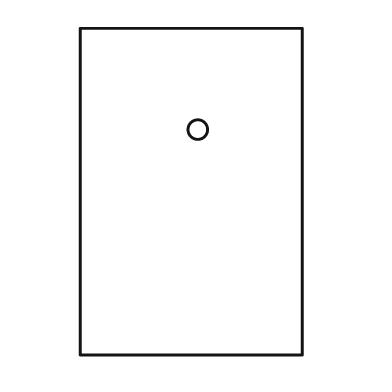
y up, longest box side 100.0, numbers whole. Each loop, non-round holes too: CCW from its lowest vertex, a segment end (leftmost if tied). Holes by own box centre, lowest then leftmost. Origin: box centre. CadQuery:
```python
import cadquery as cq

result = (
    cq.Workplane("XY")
    .moveTo(-34.0, -50.0)
    .lineTo(34.0, -50.0)
    .lineTo(34.0, 50.0)
    .lineTo(-34.0, 50.0)
    .close()
    .moveTo(2.0, 19.0)
    .circle(3.0)
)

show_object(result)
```